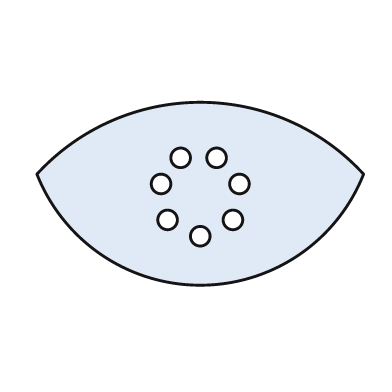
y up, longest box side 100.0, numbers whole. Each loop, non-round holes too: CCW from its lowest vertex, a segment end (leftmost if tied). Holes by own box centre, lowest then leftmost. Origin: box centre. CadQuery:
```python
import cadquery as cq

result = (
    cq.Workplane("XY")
    .moveTo(-50.0, 6.0)
    .threePointArc((0.0, -28.0), (50.0, 6.0))
    .threePointArc((0.0, 28.0), (-50.0, 6.0))
    .close()
    .moveTo(0.0, -13.0)
    .circle(3.0)
    .moveTo(-10.0, -8.0)
    .circle(3.0)
    .moveTo(10.0, -8.0)
    .circle(3.0)
    .moveTo(-12.0, 3.0)
    .circle(3.0)
    .moveTo(12.0, 3.0)
    .circle(3.0)
    .moveTo(-6.0, 11.0)
    .circle(3.0)
    .moveTo(5.0, 11.0)
    .circle(3.0)
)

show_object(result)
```